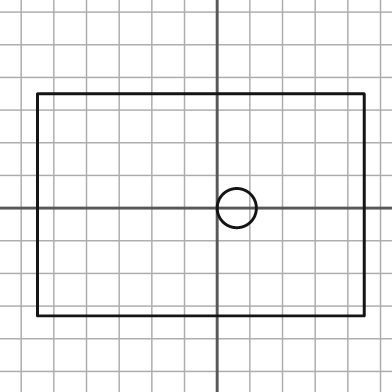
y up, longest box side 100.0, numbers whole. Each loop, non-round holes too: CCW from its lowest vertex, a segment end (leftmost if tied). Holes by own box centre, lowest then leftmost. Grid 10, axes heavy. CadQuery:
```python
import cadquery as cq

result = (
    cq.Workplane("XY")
    .moveTo(-55.0, -33.0)
    .lineTo(45.0, -33.0)
    .lineTo(45.0, 35.0)
    .lineTo(-55.0, 35.0)
    .close()
    .moveTo(6.0, 0.0)
    .circle(6.0)
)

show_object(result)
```